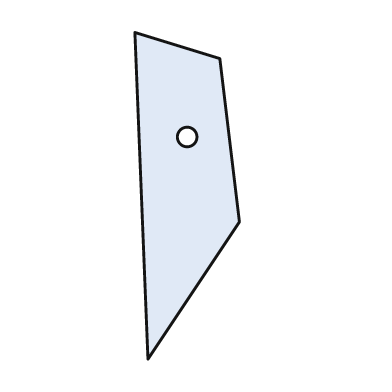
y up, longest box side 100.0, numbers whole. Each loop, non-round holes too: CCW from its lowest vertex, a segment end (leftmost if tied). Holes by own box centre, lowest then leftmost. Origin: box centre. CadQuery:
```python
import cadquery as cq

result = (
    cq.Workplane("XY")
    .moveTo(-12.0, -50.0)
    .lineTo(16.0, -8.0)
    .lineTo(10.0, 42.0)
    .lineTo(-16.0, 50.0)
    .close()
    .moveTo(0.0, 18.0)
    .circle(3.0)
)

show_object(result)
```